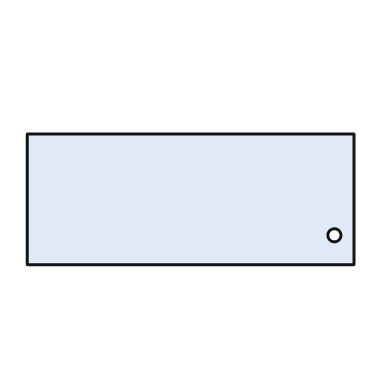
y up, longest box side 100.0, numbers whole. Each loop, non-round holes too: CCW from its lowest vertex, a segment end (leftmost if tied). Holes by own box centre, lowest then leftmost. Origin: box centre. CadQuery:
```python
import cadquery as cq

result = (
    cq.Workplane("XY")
    .moveTo(-50.0, -20.0)
    .lineTo(50.0, -20.0)
    .lineTo(50.0, 20.0)
    .lineTo(-50.0, 20.0)
    .close()
    .moveTo(44.0, -11.0)
    .circle(2.0)
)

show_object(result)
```